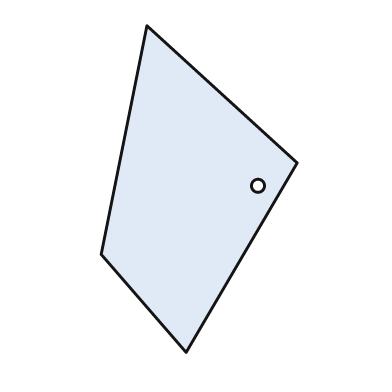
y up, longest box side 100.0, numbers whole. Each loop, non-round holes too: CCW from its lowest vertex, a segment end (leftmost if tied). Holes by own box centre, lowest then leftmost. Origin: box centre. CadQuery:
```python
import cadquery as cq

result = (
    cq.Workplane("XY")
    .moveTo(-4.0, -50.0)
    .lineTo(30.0, 8.0)
    .lineTo(-16.0, 50.0)
    .lineTo(-30.0, -20.0)
    .close()
    .moveTo(18.0, 1.0)
    .circle(2.0)
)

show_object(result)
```